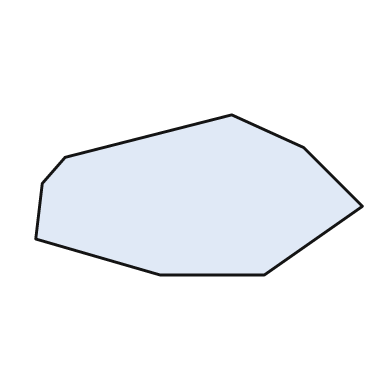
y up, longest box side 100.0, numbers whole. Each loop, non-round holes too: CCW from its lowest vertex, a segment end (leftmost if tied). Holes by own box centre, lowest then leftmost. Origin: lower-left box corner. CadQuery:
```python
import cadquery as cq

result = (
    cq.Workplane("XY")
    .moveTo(38.0, 0.0)
    .lineTo(70.0, 0.0)
    .lineTo(100.0, 21.0)
    .lineTo(82.0, 39.0)
    .lineTo(60.0, 49.0)
    .lineTo(9.0, 36.0)
    .lineTo(2.0, 28.0)
    .lineTo(0.0, 11.0)
    .close()
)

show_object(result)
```